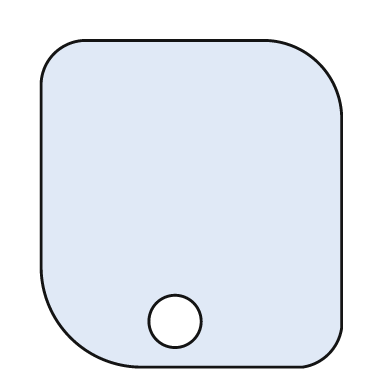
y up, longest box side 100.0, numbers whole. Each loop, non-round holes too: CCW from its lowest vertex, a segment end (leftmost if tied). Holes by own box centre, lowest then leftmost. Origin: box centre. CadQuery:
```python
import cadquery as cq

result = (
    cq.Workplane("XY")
    .moveTo(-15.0, -50.0)
    .lineTo(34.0, -50.0)
    .threePointArc((42.0, -46.0), (46.0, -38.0))
    .lineTo(46.0, 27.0)
    .threePointArc((39.0, 43.0), (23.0, 50.0))
    .lineTo(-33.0, 50.0)
    .threePointArc((-42.0, 46.0), (-46.0, 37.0))
    .lineTo(-46.0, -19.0)
    .threePointArc((-37.0, -41.0), (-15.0, -50.0))
    .close()
    .moveTo(-5.0, -36.0)
    .circle(8.0)
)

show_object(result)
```